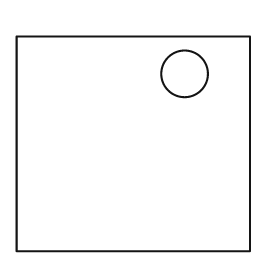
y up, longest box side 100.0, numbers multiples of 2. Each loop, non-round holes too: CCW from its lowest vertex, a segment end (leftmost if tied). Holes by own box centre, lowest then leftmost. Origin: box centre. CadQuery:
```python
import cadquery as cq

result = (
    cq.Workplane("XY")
    .moveTo(-50.0, -46.0)
    .lineTo(50.0, -46.0)
    .lineTo(50.0, 46.0)
    .lineTo(-50.0, 46.0)
    .close()
    .moveTo(22.0, 30.0)
    .circle(10.0)
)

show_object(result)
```